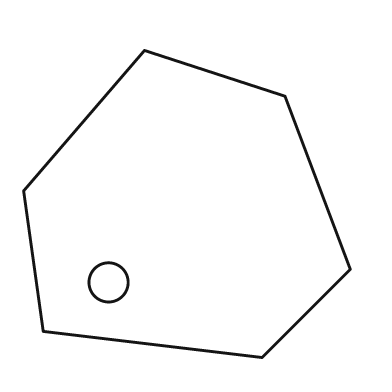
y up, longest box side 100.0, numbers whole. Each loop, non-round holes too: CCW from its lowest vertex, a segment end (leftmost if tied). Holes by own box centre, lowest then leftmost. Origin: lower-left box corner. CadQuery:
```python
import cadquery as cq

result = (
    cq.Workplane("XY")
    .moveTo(73.0, 0.0)
    .lineTo(100.0, 27.0)
    .lineTo(80.0, 80.0)
    .lineTo(37.0, 94.0)
    .lineTo(0.0, 51.0)
    .lineTo(6.0, 8.0)
    .close()
    .moveTo(26.0, 23.0)
    .circle(6.0)
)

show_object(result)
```